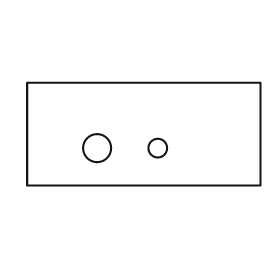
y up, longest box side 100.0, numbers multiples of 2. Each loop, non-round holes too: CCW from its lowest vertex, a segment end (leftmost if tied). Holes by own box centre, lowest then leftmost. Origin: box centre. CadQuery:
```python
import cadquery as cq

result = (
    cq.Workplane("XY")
    .moveTo(-50.0, -22.0)
    .lineTo(50.0, -22.0)
    .lineTo(50.0, 22.0)
    .lineTo(-50.0, 22.0)
    .close()
    .moveTo(-20.0, -6.0)
    .circle(6.0)
    .moveTo(6.0, -6.0)
    .circle(4.0)
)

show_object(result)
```